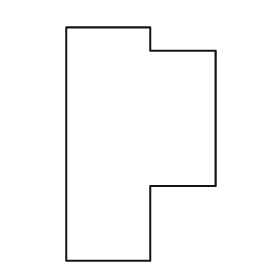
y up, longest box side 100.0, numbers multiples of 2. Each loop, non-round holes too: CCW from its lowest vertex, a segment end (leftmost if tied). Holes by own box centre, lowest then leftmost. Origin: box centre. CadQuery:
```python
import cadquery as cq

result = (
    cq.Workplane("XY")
    .moveTo(-32.0, -50.0)
    .lineTo(4.0, -50.0)
    .lineTo(4.0, -18.0)
    .lineTo(32.0, -18.0)
    .lineTo(32.0, 40.0)
    .lineTo(4.0, 40.0)
    .lineTo(4.0, 50.0)
    .lineTo(-32.0, 50.0)
    .close()
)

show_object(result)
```